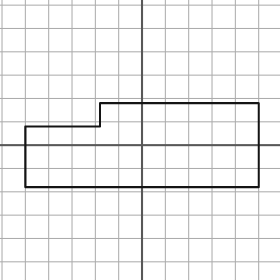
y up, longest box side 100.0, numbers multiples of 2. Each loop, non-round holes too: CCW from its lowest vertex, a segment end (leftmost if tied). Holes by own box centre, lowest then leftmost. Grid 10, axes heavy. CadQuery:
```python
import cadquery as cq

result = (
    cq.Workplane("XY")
    .moveTo(-50.0, -18.0)
    .lineTo(50.0, -18.0)
    .lineTo(50.0, 18.0)
    .lineTo(-18.0, 18.0)
    .lineTo(-18.0, 8.0)
    .lineTo(-50.0, 8.0)
    .close()
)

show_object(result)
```